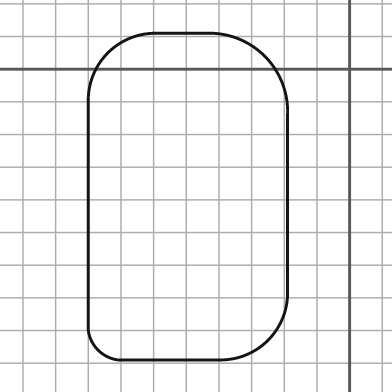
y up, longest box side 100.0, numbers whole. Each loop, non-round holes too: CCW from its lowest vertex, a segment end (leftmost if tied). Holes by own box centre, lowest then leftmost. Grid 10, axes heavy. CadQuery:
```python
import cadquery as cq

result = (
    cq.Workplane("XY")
    .moveTo(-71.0, -89.0)
    .lineTo(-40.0, -89.0)
    .threePointArc((-25.0, -83.0), (-19.0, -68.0))
    .lineTo(-19.0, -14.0)
    .threePointArc((-26.0, 4.0), (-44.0, 11.0))
    .lineTo(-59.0, 11.0)
    .threePointArc((-74.0, 5.0), (-80.0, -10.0))
    .lineTo(-80.0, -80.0)
    .threePointArc((-77.0, -86.0), (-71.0, -89.0))
    .close()
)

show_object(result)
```